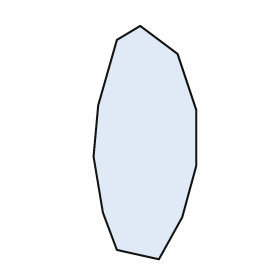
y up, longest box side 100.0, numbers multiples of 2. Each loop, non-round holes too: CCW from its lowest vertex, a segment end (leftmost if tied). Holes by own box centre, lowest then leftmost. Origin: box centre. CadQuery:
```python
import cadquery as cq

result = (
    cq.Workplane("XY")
    .moveTo(6.0, -50.0)
    .lineTo(16.0, -32.0)
    .lineTo(22.0, -10.0)
    .lineTo(22.0, 14.0)
    .lineTo(14.0, 38.0)
    .lineTo(-2.0, 50.0)
    .lineTo(-12.0, 44.0)
    .lineTo(-20.0, 16.0)
    .lineTo(-22.0, -6.0)
    .lineTo(-18.0, -30.0)
    .lineTo(-12.0, -46.0)
    .close()
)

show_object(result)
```